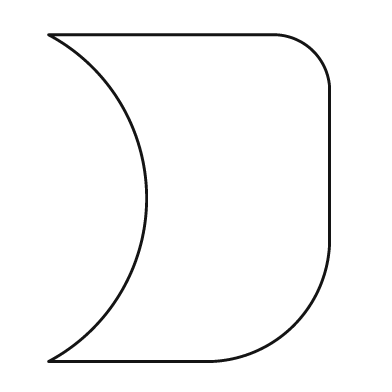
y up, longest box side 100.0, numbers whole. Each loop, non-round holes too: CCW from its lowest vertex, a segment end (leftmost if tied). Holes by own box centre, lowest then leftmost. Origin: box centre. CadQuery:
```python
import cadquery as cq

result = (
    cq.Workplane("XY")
    .moveTo(-43.0, -50.0)
    .lineTo(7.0, -50.0)
    .threePointArc((32.0, -39.0), (43.0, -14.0))
    .lineTo(43.0, 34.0)
    .threePointArc((38.0, 45.0), (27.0, 50.0))
    .lineTo(-43.0, 50.0)
    .threePointArc((-13.0, 0.0), (-43.0, -50.0))
    .close()
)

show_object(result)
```